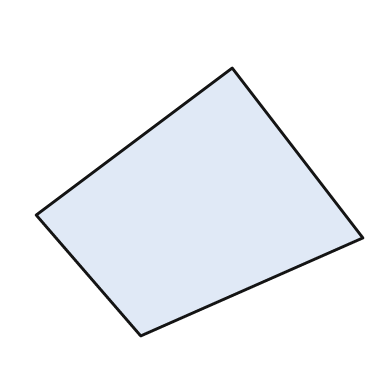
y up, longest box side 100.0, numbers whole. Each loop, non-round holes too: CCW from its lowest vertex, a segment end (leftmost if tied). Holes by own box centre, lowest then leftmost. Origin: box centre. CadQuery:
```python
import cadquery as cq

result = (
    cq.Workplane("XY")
    .moveTo(-18.0, -41.0)
    .lineTo(50.0, -11.0)
    .lineTo(10.0, 41.0)
    .lineTo(-50.0, -4.0)
    .close()
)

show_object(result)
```